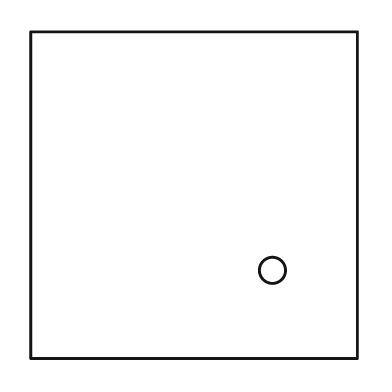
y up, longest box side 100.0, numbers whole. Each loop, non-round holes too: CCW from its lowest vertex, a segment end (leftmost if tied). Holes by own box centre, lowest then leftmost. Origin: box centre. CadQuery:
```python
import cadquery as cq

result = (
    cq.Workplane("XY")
    .moveTo(-50.0, -50.0)
    .lineTo(50.0, -50.0)
    .lineTo(50.0, 50.0)
    .lineTo(-50.0, 50.0)
    .close()
    .moveTo(24.0, -23.0)
    .circle(4.0)
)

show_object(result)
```